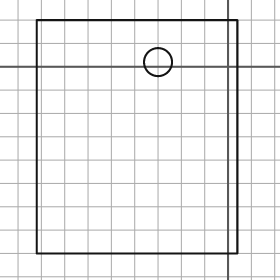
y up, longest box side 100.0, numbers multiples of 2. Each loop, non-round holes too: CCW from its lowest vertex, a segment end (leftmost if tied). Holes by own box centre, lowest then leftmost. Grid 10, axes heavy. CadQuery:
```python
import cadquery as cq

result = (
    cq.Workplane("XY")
    .moveTo(-82.0, -80.0)
    .lineTo(4.0, -80.0)
    .lineTo(4.0, 20.0)
    .lineTo(-82.0, 20.0)
    .close()
    .moveTo(-30.0, 2.0)
    .circle(6.0)
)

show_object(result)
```